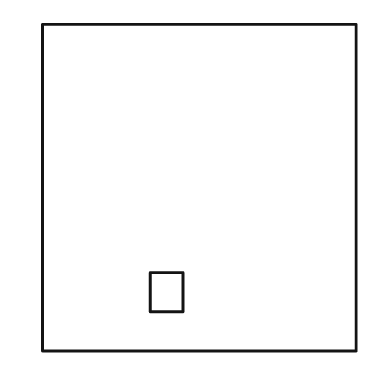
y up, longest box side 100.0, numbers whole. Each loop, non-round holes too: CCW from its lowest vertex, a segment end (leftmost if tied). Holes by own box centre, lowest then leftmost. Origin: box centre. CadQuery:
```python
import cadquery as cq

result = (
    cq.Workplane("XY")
    .moveTo(-48.0, -50.0)
    .lineTo(48.0, -50.0)
    .lineTo(48.0, 50.0)
    .lineTo(-48.0, 50.0)
    .close()
    .moveTo(-15.0, -38.0)
    .lineTo(-5.0, -38.0)
    .lineTo(-5.0, -26.0)
    .lineTo(-15.0, -26.0)
    .close()
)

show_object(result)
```